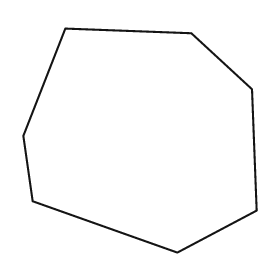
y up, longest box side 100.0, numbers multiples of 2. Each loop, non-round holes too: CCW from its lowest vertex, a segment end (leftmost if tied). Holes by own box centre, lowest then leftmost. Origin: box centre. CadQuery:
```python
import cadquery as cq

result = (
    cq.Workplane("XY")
    .moveTo(16.0, -48.0)
    .lineTo(50.0, -30.0)
    .lineTo(48.0, 22.0)
    .lineTo(22.0, 46.0)
    .lineTo(-32.0, 48.0)
    .lineTo(-50.0, 2.0)
    .lineTo(-46.0, -26.0)
    .close()
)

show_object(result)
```